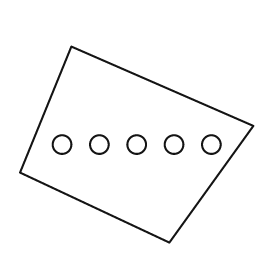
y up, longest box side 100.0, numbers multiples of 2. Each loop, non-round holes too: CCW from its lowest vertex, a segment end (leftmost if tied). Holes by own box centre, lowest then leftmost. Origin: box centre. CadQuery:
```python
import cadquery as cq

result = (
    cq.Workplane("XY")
    .moveTo(14.0, -42.0)
    .lineTo(50.0, 8.0)
    .lineTo(-28.0, 42.0)
    .lineTo(-50.0, -12.0)
    .close()
    .moveTo(-32.0, 0.0)
    .circle(4.0)
    .moveTo(-16.0, 0.0)
    .circle(4.0)
    .moveTo(0.0, 0.0)
    .circle(4.0)
    .moveTo(16.0, 0.0)
    .circle(4.0)
    .moveTo(32.0, 0.0)
    .circle(4.0)
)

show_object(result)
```